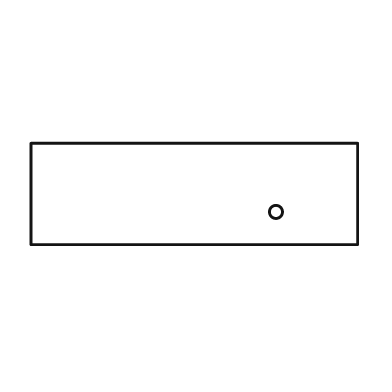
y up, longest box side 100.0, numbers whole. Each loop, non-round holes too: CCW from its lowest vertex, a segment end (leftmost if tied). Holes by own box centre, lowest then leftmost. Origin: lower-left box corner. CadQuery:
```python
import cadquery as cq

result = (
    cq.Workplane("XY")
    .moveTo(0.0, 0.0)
    .lineTo(100.0, 0.0)
    .lineTo(100.0, 31.0)
    .lineTo(0.0, 31.0)
    .close()
    .moveTo(75.0, 10.0)
    .circle(2.0)
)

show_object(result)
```